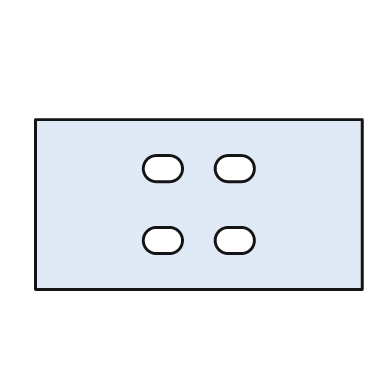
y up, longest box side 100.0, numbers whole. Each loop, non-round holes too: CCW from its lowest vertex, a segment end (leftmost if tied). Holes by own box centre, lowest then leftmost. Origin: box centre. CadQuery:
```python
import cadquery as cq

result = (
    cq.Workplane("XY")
    .moveTo(-50.0, -26.0)
    .lineTo(50.0, -26.0)
    .lineTo(50.0, 26.0)
    .lineTo(-50.0, 26.0)
    .close()
    .moveTo(-13.0, -15.0)
    .lineTo(-9.0, -15.0)
    .threePointArc((-5.0, -11.0), (-9.0, -7.0))
    .lineTo(-13.0, -7.0)
    .threePointArc((-17.0, -11.0), (-13.0, -15.0))
    .close()
    .moveTo(9.0, -15.0)
    .lineTo(13.0, -15.0)
    .threePointArc((17.0, -11.0), (13.0, -7.0))
    .lineTo(9.0, -7.0)
    .threePointArc((5.0, -11.0), (9.0, -15.0))
    .close()
    .moveTo(-13.0, 7.0)
    .lineTo(-9.0, 7.0)
    .threePointArc((-5.0, 11.0), (-9.0, 15.0))
    .lineTo(-13.0, 15.0)
    .threePointArc((-17.0, 11.0), (-13.0, 7.0))
    .close()
    .moveTo(9.0, 7.0)
    .lineTo(13.0, 7.0)
    .threePointArc((17.0, 11.0), (13.0, 15.0))
    .lineTo(9.0, 15.0)
    .threePointArc((5.0, 11.0), (9.0, 7.0))
    .close()
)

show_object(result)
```